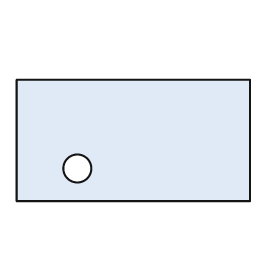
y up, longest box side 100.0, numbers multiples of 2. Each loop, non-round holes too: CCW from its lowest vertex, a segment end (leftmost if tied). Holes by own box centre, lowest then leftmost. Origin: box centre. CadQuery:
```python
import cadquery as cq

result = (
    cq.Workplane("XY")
    .moveTo(-50.0, -26.0)
    .lineTo(50.0, -26.0)
    .lineTo(50.0, 26.0)
    .lineTo(-50.0, 26.0)
    .close()
    .moveTo(-24.0, -12.0)
    .circle(6.0)
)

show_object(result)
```